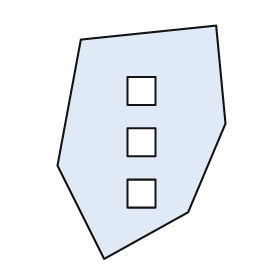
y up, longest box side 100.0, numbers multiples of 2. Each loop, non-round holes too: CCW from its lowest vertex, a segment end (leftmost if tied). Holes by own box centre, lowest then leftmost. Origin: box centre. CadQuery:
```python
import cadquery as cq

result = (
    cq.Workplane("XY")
    .moveTo(-16.0, -50.0)
    .lineTo(20.0, -30.0)
    .lineTo(36.0, 8.0)
    .lineTo(32.0, 50.0)
    .lineTo(-26.0, 44.0)
    .lineTo(-36.0, -10.0)
    .close()
    .moveTo(-6.0, -28.0)
    .lineTo(6.0, -28.0)
    .lineTo(6.0, -16.0)
    .lineTo(-6.0, -16.0)
    .close()
    .moveTo(-6.0, -6.0)
    .lineTo(6.0, -6.0)
    .lineTo(6.0, 6.0)
    .lineTo(-6.0, 6.0)
    .close()
    .moveTo(-6.0, 16.0)
    .lineTo(6.0, 16.0)
    .lineTo(6.0, 28.0)
    .lineTo(-6.0, 28.0)
    .close()
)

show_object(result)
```